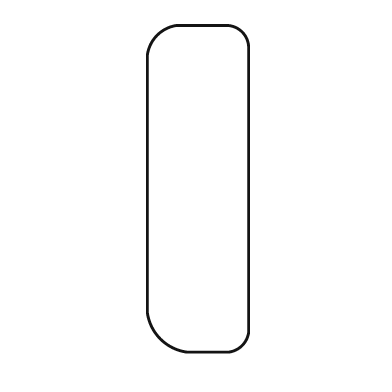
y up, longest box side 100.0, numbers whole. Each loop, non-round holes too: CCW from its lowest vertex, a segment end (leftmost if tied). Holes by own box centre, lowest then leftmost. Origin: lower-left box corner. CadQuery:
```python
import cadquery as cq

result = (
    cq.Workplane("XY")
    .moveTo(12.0, 0.0)
    .lineTo(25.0, 0.0)
    .threePointArc((29.0, 2.0), (31.0, 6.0))
    .lineTo(31.0, 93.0)
    .threePointArc((29.0, 98.0), (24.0, 100.0))
    .lineTo(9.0, 100.0)
    .threePointArc((3.0, 97.0), (0.0, 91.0))
    .lineTo(0.0, 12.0)
    .threePointArc((4.0, 4.0), (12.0, 0.0))
    .close()
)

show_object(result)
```